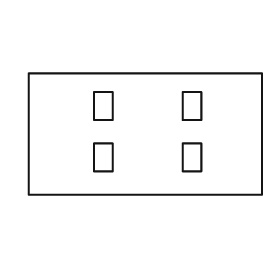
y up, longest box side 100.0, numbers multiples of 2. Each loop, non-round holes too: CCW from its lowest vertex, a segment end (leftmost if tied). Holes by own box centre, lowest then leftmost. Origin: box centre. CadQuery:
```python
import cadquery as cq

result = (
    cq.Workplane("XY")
    .moveTo(-50.0, -26.0)
    .lineTo(50.0, -26.0)
    .lineTo(50.0, 26.0)
    .lineTo(-50.0, 26.0)
    .close()
    .moveTo(-22.0, -16.0)
    .lineTo(-14.0, -16.0)
    .lineTo(-14.0, -4.0)
    .lineTo(-22.0, -4.0)
    .close()
    .moveTo(16.0, -16.0)
    .lineTo(24.0, -16.0)
    .lineTo(24.0, -4.0)
    .lineTo(16.0, -4.0)
    .close()
    .moveTo(-22.0, 6.0)
    .lineTo(-14.0, 6.0)
    .lineTo(-14.0, 18.0)
    .lineTo(-22.0, 18.0)
    .close()
    .moveTo(16.0, 6.0)
    .lineTo(24.0, 6.0)
    .lineTo(24.0, 18.0)
    .lineTo(16.0, 18.0)
    .close()
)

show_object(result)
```